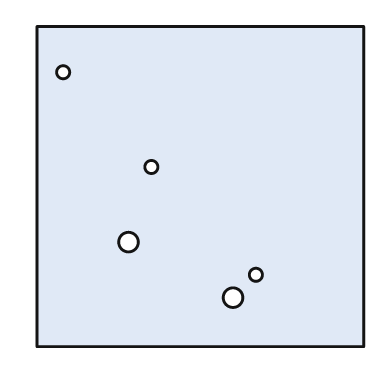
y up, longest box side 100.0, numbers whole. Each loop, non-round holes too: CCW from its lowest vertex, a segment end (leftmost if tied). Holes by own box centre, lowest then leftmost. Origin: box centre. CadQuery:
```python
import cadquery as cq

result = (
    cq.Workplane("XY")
    .moveTo(-50.0, -49.0)
    .lineTo(50.0, -49.0)
    .lineTo(50.0, 49.0)
    .lineTo(-50.0, 49.0)
    .close()
    .moveTo(10.0, -34.0)
    .circle(3.0)
    .moveTo(17.0, -27.0)
    .circle(2.0)
    .moveTo(-22.0, -17.0)
    .circle(3.0)
    .moveTo(-15.0, 6.0)
    .circle(2.0)
    .moveTo(-42.0, 35.0)
    .circle(2.0)
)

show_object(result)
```